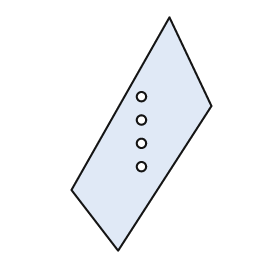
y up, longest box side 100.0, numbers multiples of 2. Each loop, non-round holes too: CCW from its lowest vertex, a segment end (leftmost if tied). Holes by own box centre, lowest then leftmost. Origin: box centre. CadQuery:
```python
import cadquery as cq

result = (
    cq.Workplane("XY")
    .moveTo(-10.0, -50.0)
    .lineTo(30.0, 12.0)
    .lineTo(12.0, 50.0)
    .lineTo(-30.0, -24.0)
    .close()
    .moveTo(0.0, -14.0)
    .circle(2.0)
    .moveTo(0.0, -4.0)
    .circle(2.0)
    .moveTo(0.0, 6.0)
    .circle(2.0)
    .moveTo(0.0, 16.0)
    .circle(2.0)
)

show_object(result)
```